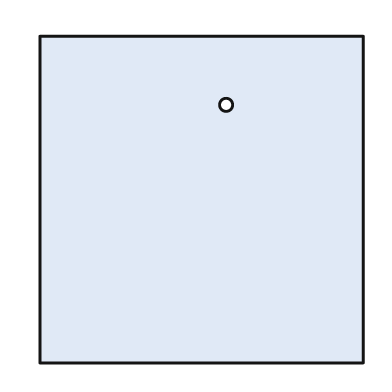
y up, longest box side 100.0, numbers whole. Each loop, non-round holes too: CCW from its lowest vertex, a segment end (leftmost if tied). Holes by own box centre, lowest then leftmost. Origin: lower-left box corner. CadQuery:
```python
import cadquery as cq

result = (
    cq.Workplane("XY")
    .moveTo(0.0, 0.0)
    .lineTo(99.0, 0.0)
    .lineTo(99.0, 100.0)
    .lineTo(0.0, 100.0)
    .close()
    .moveTo(57.0, 79.0)
    .circle(2.0)
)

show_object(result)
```